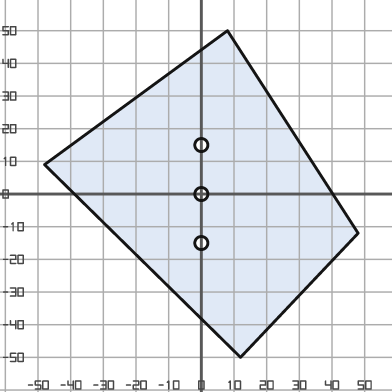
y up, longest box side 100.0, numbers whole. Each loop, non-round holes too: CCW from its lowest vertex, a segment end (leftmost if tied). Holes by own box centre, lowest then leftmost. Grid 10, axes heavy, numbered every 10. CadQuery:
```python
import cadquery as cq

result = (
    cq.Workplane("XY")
    .moveTo(12.0, -50.0)
    .lineTo(48.0, -12.0)
    .lineTo(8.0, 50.0)
    .lineTo(-48.0, 9.0)
    .close()
    .moveTo(0.0, -15.0)
    .circle(2.0)
    .moveTo(0.0, 0.0)
    .circle(2.0)
    .moveTo(0.0, 15.0)
    .circle(2.0)
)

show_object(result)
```